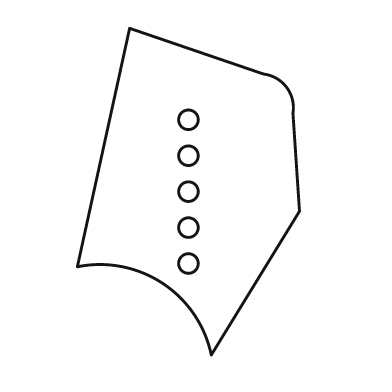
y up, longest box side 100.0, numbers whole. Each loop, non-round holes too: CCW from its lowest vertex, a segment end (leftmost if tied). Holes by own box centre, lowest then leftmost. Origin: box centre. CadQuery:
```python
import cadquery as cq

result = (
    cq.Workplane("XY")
    .moveTo(7.0, -50.0)
    .lineTo(34.0, -6.0)
    .lineTo(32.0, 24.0)
    .threePointArc((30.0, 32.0), (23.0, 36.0))
    .lineTo(-18.0, 50.0)
    .lineTo(-34.0, -23.0)
    .threePointArc((-8.0, -28.0), (7.0, -50.0))
    .close()
    .moveTo(0.0, -22.0)
    .circle(3.0)
    .moveTo(0.0, -11.0)
    .circle(3.0)
    .moveTo(0.0, 0.0)
    .circle(3.0)
    .moveTo(0.0, 11.0)
    .circle(3.0)
    .moveTo(0.0, 22.0)
    .circle(3.0)
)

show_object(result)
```